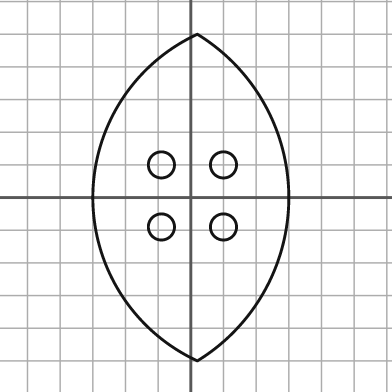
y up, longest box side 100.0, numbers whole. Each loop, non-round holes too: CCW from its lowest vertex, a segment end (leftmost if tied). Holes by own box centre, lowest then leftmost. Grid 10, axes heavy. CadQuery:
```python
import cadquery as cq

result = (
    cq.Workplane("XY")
    .moveTo(2.0, -50.0)
    .threePointArc((30.0, 0.0), (2.0, 50.0))
    .threePointArc((-30.0, 0.0), (2.0, -50.0))
    .close()
    .moveTo(-9.0, -9.0)
    .circle(4.0)
    .moveTo(10.0, -9.0)
    .circle(4.0)
    .moveTo(-9.0, 10.0)
    .circle(4.0)
    .moveTo(10.0, 10.0)
    .circle(4.0)
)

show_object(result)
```